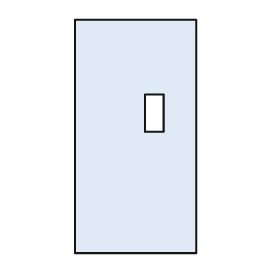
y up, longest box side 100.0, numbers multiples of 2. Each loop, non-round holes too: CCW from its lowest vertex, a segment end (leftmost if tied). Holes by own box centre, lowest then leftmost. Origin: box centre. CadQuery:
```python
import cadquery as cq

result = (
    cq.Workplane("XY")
    .moveTo(-26.0, -50.0)
    .lineTo(26.0, -50.0)
    .lineTo(26.0, 50.0)
    .lineTo(-26.0, 50.0)
    .close()
    .moveTo(4.0, 2.0)
    .lineTo(12.0, 2.0)
    .lineTo(12.0, 18.0)
    .lineTo(4.0, 18.0)
    .close()
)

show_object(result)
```